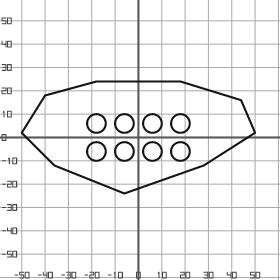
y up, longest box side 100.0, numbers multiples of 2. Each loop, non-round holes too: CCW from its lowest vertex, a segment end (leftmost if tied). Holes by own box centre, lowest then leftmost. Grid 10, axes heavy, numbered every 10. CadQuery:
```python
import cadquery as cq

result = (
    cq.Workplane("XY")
    .moveTo(-6.0, -24.0)
    .lineTo(28.0, -12.0)
    .lineTo(50.0, 2.0)
    .lineTo(44.0, 16.0)
    .lineTo(18.0, 24.0)
    .lineTo(-18.0, 24.0)
    .lineTo(-40.0, 18.0)
    .lineTo(-50.0, 2.0)
    .lineTo(-36.0, -12.0)
    .close()
    .moveTo(-18.0, -6.0)
    .circle(4.0)
    .moveTo(-6.0, -6.0)
    .circle(4.0)
    .moveTo(6.0, -6.0)
    .circle(4.0)
    .moveTo(18.0, -6.0)
    .circle(4.0)
    .moveTo(-18.0, 6.0)
    .circle(4.0)
    .moveTo(-6.0, 6.0)
    .circle(4.0)
    .moveTo(6.0, 6.0)
    .circle(4.0)
    .moveTo(18.0, 6.0)
    .circle(4.0)
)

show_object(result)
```